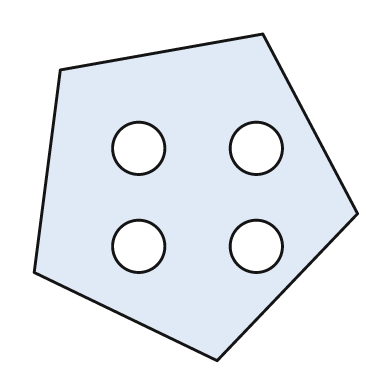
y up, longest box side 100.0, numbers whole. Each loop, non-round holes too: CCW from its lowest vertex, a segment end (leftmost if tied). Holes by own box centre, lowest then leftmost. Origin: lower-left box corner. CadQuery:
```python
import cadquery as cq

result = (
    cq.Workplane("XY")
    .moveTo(56.0, 0.0)
    .lineTo(99.0, 45.0)
    .lineTo(70.0, 100.0)
    .lineTo(8.0, 89.0)
    .lineTo(0.0, 27.0)
    .close()
    .moveTo(32.0, 35.0)
    .circle(8.0)
    .moveTo(68.0, 35.0)
    .circle(8.0)
    .moveTo(32.0, 65.0)
    .circle(8.0)
    .moveTo(68.0, 65.0)
    .circle(8.0)
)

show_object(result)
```